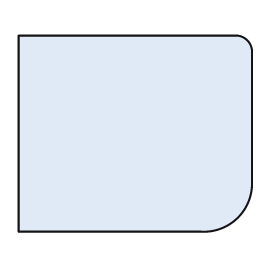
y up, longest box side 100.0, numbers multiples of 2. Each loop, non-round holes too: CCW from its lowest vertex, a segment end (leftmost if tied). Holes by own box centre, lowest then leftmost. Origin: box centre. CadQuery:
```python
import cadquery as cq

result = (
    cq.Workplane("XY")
    .moveTo(-50.0, -42.0)
    .lineTo(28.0, -42.0)
    .threePointArc((44.0, -36.0), (50.0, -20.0))
    .lineTo(50.0, 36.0)
    .threePointArc((48.0, 40.0), (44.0, 42.0))
    .lineTo(-50.0, 42.0)
    .close()
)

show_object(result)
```